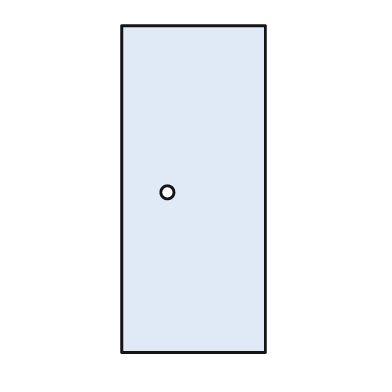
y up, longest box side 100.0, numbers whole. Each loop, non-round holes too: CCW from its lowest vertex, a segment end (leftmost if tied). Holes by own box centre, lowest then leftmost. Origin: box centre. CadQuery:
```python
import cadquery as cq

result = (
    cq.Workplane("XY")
    .moveTo(-22.0, -50.0)
    .lineTo(22.0, -50.0)
    .lineTo(22.0, 50.0)
    .lineTo(-22.0, 50.0)
    .close()
    .moveTo(-8.0, -1.0)
    .circle(2.0)
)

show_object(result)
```